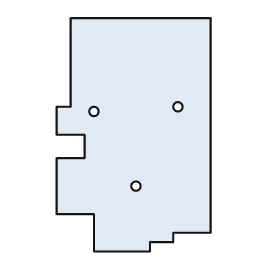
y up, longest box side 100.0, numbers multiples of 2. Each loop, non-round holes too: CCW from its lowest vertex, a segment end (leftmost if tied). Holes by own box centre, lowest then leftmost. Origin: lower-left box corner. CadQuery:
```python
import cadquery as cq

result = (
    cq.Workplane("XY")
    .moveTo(16.0, 0.0)
    .lineTo(40.0, 0.0)
    .lineTo(40.0, 4.0)
    .lineTo(50.0, 4.0)
    .lineTo(50.0, 8.0)
    .lineTo(66.0, 8.0)
    .lineTo(66.0, 100.0)
    .lineTo(6.0, 100.0)
    .lineTo(6.0, 62.0)
    .lineTo(0.0, 62.0)
    .lineTo(0.0, 50.0)
    .lineTo(12.0, 50.0)
    .lineTo(12.0, 40.0)
    .lineTo(0.0, 40.0)
    .lineTo(0.0, 16.0)
    .lineTo(16.0, 16.0)
    .close()
    .moveTo(34.0, 28.0)
    .circle(2.0)
    .moveTo(16.0, 60.0)
    .circle(2.0)
    .moveTo(52.0, 62.0)
    .circle(2.0)
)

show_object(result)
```